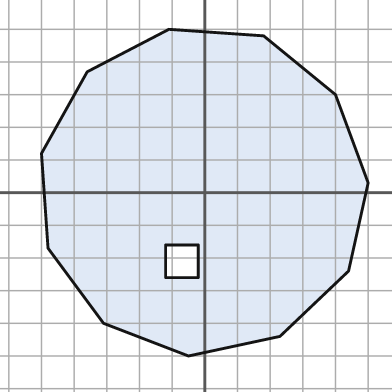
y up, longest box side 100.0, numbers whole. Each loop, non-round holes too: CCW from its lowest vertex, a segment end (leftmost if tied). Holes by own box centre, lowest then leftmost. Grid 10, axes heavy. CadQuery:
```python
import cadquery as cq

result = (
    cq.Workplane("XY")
    .moveTo(-5.0, -50.0)
    .lineTo(23.0, -44.0)
    .lineTo(44.0, -24.0)
    .lineTo(50.0, 3.0)
    .lineTo(40.0, 30.0)
    .lineTo(18.0, 48.0)
    .lineTo(-11.0, 50.0)
    .lineTo(-36.0, 37.0)
    .lineTo(-50.0, 12.0)
    .lineTo(-48.0, -17.0)
    .lineTo(-31.0, -40.0)
    .close()
    .moveTo(-12.0, -26.0)
    .lineTo(-2.0, -26.0)
    .lineTo(-2.0, -16.0)
    .lineTo(-12.0, -16.0)
    .close()
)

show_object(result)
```